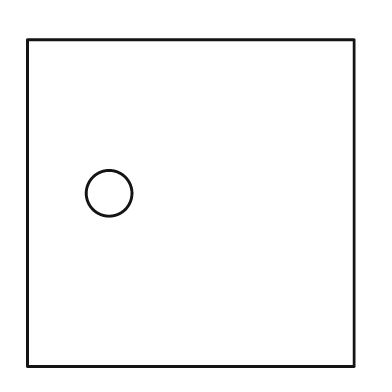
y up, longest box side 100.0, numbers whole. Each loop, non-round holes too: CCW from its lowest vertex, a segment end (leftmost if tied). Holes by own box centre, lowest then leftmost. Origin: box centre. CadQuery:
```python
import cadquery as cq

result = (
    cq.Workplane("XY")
    .moveTo(-50.0, -50.0)
    .lineTo(50.0, -50.0)
    .lineTo(50.0, 50.0)
    .lineTo(-50.0, 50.0)
    .close()
    .moveTo(-25.0, 3.0)
    .circle(7.0)
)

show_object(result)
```